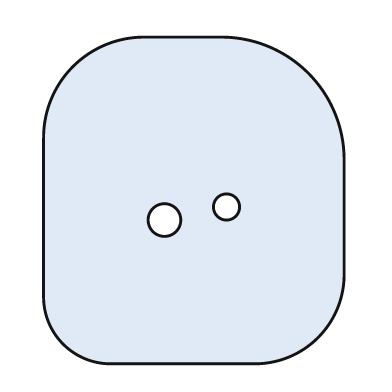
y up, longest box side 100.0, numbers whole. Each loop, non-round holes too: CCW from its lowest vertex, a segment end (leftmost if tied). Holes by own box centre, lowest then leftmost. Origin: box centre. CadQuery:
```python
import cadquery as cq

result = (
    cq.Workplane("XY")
    .moveTo(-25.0, -50.0)
    .lineTo(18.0, -50.0)
    .threePointArc((38.0, -42.0), (46.0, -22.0))
    .lineTo(46.0, 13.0)
    .threePointArc((35.0, 39.0), (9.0, 50.0))
    .lineTo(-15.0, 50.0)
    .threePointArc((-37.0, 41.0), (-46.0, 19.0))
    .lineTo(-46.0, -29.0)
    .threePointArc((-40.0, -44.0), (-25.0, -50.0))
    .close()
    .moveTo(-9.0, -6.0)
    .circle(5.0)
    .moveTo(10.0, -2.0)
    .circle(4.0)
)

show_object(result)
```